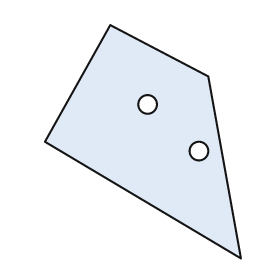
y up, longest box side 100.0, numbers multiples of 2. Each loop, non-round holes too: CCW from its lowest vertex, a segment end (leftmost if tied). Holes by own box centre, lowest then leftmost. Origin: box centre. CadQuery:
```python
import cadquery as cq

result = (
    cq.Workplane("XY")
    .moveTo(42.0, -50.0)
    .lineTo(28.0, 28.0)
    .lineTo(-14.0, 50.0)
    .lineTo(-42.0, 0.0)
    .close()
    .moveTo(24.0, -4.0)
    .circle(4.0)
    .moveTo(2.0, 16.0)
    .circle(4.0)
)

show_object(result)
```